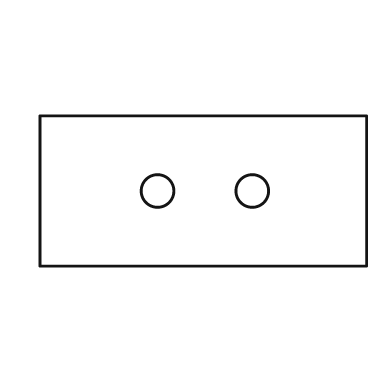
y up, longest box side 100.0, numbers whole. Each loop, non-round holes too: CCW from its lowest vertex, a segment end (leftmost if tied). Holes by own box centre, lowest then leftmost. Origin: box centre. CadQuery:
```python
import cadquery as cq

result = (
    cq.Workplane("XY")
    .moveTo(-50.0, -23.0)
    .lineTo(50.0, -23.0)
    .lineTo(50.0, 23.0)
    .lineTo(-50.0, 23.0)
    .close()
    .moveTo(-14.0, 0.0)
    .circle(5.0)
    .moveTo(15.0, 0.0)
    .circle(5.0)
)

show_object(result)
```